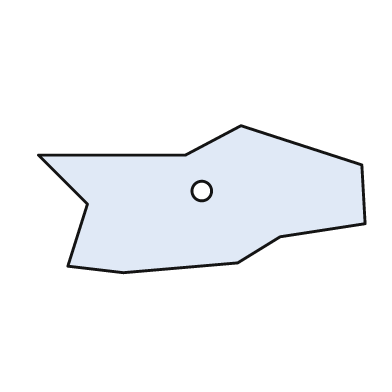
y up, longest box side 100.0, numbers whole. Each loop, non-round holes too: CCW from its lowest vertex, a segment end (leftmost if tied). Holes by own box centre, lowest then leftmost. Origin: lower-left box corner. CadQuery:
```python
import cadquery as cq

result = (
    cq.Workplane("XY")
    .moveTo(26.0, 0.0)
    .lineTo(61.0, 3.0)
    .lineTo(74.0, 11.0)
    .lineTo(100.0, 15.0)
    .lineTo(99.0, 33.0)
    .lineTo(62.0, 45.0)
    .lineTo(45.0, 36.0)
    .lineTo(0.0, 36.0)
    .lineTo(15.0, 21.0)
    .lineTo(9.0, 2.0)
    .close()
    .moveTo(50.0, 25.0)
    .circle(3.0)
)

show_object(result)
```